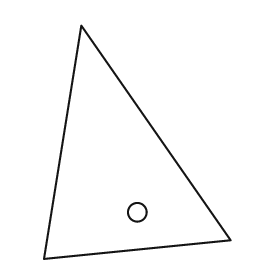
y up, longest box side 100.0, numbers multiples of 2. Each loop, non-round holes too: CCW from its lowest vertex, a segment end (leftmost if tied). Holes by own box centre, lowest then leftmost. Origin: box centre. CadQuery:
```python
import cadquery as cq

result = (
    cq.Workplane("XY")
    .moveTo(-40.0, -50.0)
    .lineTo(40.0, -42.0)
    .lineTo(-24.0, 50.0)
    .close()
    .moveTo(0.0, -30.0)
    .circle(4.0)
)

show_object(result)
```